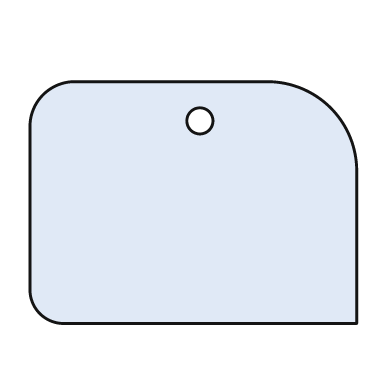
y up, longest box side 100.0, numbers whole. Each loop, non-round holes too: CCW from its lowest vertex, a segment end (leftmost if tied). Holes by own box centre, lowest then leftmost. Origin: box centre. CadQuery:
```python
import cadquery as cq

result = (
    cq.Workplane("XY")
    .moveTo(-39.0, -37.0)
    .lineTo(50.0, -37.0)
    .lineTo(50.0, 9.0)
    .threePointArc((42.0, 29.0), (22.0, 37.0))
    .lineTo(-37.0, 37.0)
    .threePointArc((-46.0, 33.0), (-50.0, 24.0))
    .lineTo(-50.0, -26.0)
    .threePointArc((-47.0, -34.0), (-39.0, -37.0))
    .close()
    .moveTo(2.0, 25.0)
    .circle(4.0)
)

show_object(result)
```